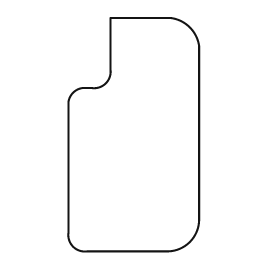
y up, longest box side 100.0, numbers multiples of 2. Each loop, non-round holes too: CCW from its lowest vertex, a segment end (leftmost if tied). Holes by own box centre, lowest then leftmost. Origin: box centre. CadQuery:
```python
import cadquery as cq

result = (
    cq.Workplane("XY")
    .moveTo(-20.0, -50.0)
    .lineTo(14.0, -50.0)
    .threePointArc((24.0, -46.0), (28.0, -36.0))
    .lineTo(28.0, 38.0)
    .threePointArc((24.0, 46.0), (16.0, 50.0))
    .lineTo(-10.0, 50.0)
    .lineTo(-10.0, 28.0)
    .threePointArc((-12.0, 22.0), (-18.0, 20.0))
    .lineTo(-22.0, 20.0)
    .threePointArc((-26.0, 18.0), (-28.0, 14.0))
    .lineTo(-28.0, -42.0)
    .threePointArc((-26.0, -48.0), (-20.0, -50.0))
    .close()
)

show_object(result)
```